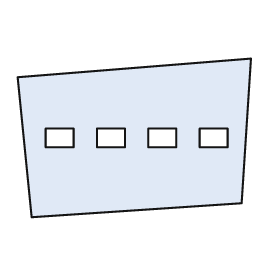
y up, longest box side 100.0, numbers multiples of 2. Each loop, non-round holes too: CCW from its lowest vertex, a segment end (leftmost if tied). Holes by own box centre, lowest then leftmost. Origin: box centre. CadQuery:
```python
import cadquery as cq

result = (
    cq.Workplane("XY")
    .moveTo(-44.0, -34.0)
    .lineTo(46.0, -28.0)
    .lineTo(50.0, 34.0)
    .lineTo(-50.0, 26.0)
    .close()
    .moveTo(-38.0, -4.0)
    .lineTo(-26.0, -4.0)
    .lineTo(-26.0, 4.0)
    .lineTo(-38.0, 4.0)
    .close()
    .moveTo(-16.0, -4.0)
    .lineTo(-4.0, -4.0)
    .lineTo(-4.0, 4.0)
    .lineTo(-16.0, 4.0)
    .close()
    .moveTo(6.0, -4.0)
    .lineTo(18.0, -4.0)
    .lineTo(18.0, 4.0)
    .lineTo(6.0, 4.0)
    .close()
    .moveTo(28.0, -4.0)
    .lineTo(40.0, -4.0)
    .lineTo(40.0, 4.0)
    .lineTo(28.0, 4.0)
    .close()
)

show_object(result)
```